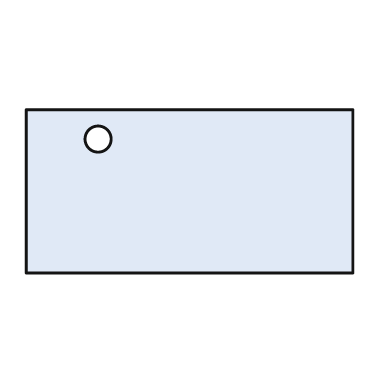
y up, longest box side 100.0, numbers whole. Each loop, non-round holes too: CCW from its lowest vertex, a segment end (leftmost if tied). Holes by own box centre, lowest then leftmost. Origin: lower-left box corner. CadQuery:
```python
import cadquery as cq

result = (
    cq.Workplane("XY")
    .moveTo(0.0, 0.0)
    .lineTo(100.0, 0.0)
    .lineTo(100.0, 50.0)
    .lineTo(0.0, 50.0)
    .close()
    .moveTo(22.0, 41.0)
    .circle(4.0)
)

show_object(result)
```